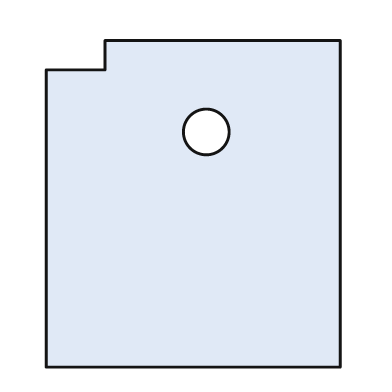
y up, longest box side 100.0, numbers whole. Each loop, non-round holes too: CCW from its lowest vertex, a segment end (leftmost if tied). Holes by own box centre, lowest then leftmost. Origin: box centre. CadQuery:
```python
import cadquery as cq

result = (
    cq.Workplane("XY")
    .moveTo(-45.0, -50.0)
    .lineTo(45.0, -50.0)
    .lineTo(45.0, 50.0)
    .lineTo(-27.0, 50.0)
    .lineTo(-27.0, 41.0)
    .lineTo(-45.0, 41.0)
    .close()
    .moveTo(4.0, 22.0)
    .circle(7.0)
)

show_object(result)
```